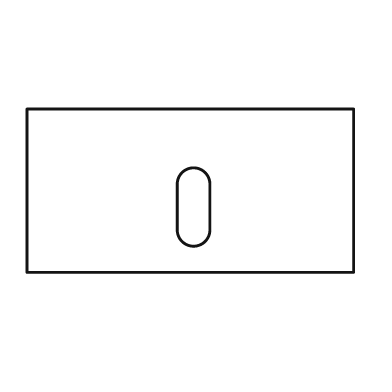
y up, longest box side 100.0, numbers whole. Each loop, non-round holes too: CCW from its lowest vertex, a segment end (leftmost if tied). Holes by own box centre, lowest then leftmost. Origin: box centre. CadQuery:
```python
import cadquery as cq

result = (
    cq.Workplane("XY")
    .moveTo(-50.0, -25.0)
    .lineTo(50.0, -25.0)
    .lineTo(50.0, 25.0)
    .lineTo(-50.0, 25.0)
    .close()
    .moveTo(-4.0, -12.0)
    .threePointArc((1.0, -17.0), (6.0, -12.0))
    .lineTo(6.0, 2.0)
    .threePointArc((1.0, 7.0), (-4.0, 2.0))
    .close()
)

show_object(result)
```